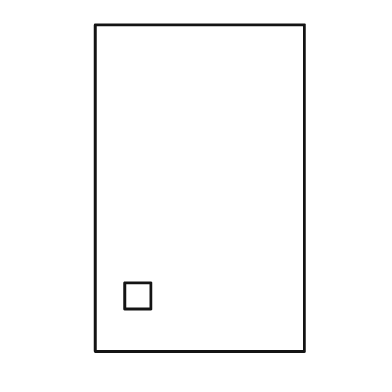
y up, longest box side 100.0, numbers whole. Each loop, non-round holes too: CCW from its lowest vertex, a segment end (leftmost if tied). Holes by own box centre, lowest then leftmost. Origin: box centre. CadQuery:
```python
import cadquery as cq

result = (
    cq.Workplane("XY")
    .moveTo(-32.0, -50.0)
    .lineTo(32.0, -50.0)
    .lineTo(32.0, 50.0)
    .lineTo(-32.0, 50.0)
    .close()
    .moveTo(-23.0, -37.0)
    .lineTo(-15.0, -37.0)
    .lineTo(-15.0, -29.0)
    .lineTo(-23.0, -29.0)
    .close()
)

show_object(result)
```